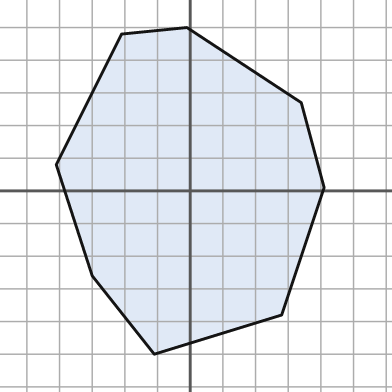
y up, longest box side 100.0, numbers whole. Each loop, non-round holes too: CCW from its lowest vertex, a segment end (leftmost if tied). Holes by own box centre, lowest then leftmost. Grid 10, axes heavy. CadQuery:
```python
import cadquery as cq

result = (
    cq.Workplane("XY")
    .moveTo(-11.0, -50.0)
    .lineTo(28.0, -38.0)
    .lineTo(41.0, 1.0)
    .lineTo(34.0, 27.0)
    .lineTo(-1.0, 50.0)
    .lineTo(-21.0, 48.0)
    .lineTo(-41.0, 8.0)
    .lineTo(-30.0, -26.0)
    .close()
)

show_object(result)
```